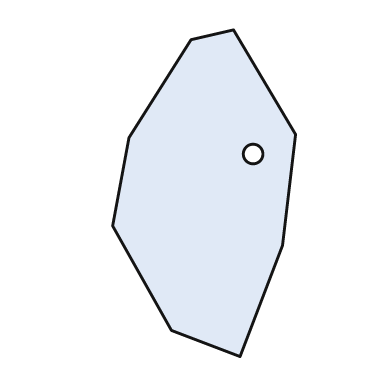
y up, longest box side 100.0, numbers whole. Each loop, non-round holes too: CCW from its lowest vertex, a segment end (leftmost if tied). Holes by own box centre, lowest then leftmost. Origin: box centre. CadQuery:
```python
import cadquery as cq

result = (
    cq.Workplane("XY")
    .moveTo(11.0, -50.0)
    .lineTo(24.0, -16.0)
    .lineTo(28.0, 18.0)
    .lineTo(9.0, 50.0)
    .lineTo(-4.0, 47.0)
    .lineTo(-23.0, 17.0)
    .lineTo(-28.0, -10.0)
    .lineTo(-10.0, -42.0)
    .close()
    .moveTo(15.0, 12.0)
    .circle(3.0)
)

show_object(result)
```